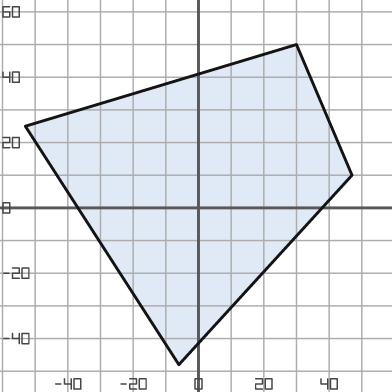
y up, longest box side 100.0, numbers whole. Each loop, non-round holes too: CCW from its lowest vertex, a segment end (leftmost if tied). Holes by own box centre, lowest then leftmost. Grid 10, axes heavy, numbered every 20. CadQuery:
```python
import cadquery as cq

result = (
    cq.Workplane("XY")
    .moveTo(-6.0, -48.0)
    .lineTo(47.0, 10.0)
    .lineTo(30.0, 50.0)
    .lineTo(-53.0, 25.0)
    .close()
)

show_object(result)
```